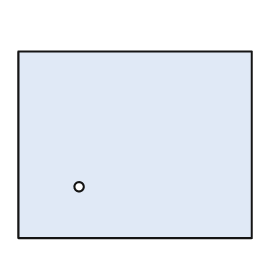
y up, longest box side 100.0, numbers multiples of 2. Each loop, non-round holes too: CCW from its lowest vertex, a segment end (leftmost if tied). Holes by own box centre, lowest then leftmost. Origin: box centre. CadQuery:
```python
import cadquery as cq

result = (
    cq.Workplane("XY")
    .moveTo(-50.0, -40.0)
    .lineTo(50.0, -40.0)
    .lineTo(50.0, 40.0)
    .lineTo(-50.0, 40.0)
    .close()
    .moveTo(-24.0, -18.0)
    .circle(2.0)
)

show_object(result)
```